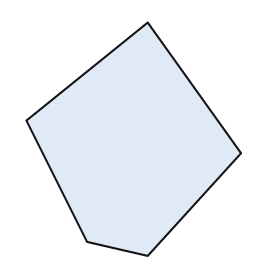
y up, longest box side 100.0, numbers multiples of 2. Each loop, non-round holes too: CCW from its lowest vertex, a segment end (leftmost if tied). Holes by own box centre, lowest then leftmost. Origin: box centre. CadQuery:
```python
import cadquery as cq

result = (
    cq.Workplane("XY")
    .moveTo(6.0, -50.0)
    .lineTo(46.0, -6.0)
    .lineTo(6.0, 50.0)
    .lineTo(-46.0, 8.0)
    .lineTo(-20.0, -44.0)
    .close()
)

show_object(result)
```